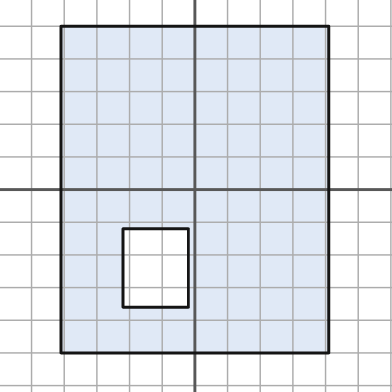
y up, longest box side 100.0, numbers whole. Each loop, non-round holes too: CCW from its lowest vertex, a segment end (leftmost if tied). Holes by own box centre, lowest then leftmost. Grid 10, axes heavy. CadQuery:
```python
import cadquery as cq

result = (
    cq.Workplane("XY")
    .moveTo(-41.0, -50.0)
    .lineTo(41.0, -50.0)
    .lineTo(41.0, 50.0)
    .lineTo(-41.0, 50.0)
    .close()
    .moveTo(-22.0, -36.0)
    .lineTo(-2.0, -36.0)
    .lineTo(-2.0, -12.0)
    .lineTo(-22.0, -12.0)
    .close()
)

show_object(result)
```